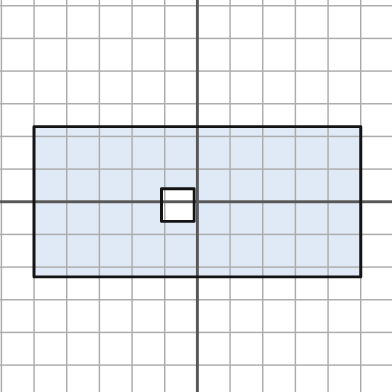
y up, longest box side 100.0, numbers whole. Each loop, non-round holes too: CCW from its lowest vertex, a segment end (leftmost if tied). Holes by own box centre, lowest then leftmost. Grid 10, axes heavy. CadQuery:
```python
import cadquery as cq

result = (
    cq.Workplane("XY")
    .moveTo(-50.0, -23.0)
    .lineTo(50.0, -23.0)
    .lineTo(50.0, 23.0)
    .lineTo(-50.0, 23.0)
    .close()
    .moveTo(-11.0, -6.0)
    .lineTo(-1.0, -6.0)
    .lineTo(-1.0, 4.0)
    .lineTo(-11.0, 4.0)
    .close()
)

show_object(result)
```